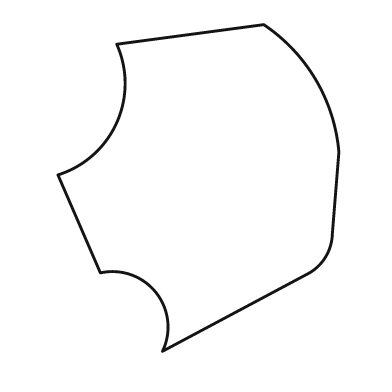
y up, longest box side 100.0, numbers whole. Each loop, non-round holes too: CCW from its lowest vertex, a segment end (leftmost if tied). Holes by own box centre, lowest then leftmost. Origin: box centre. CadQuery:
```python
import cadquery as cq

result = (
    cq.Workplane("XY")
    .moveTo(-11.0, -50.0)
    .lineTo(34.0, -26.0)
    .threePointArc((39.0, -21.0), (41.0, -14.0))
    .lineTo(43.0, 11.0)
    .threePointArc((36.0, 33.0), (20.0, 50.0))
    .lineTo(-25.0, 44.0)
    .threePointArc((-25.0, 20.0), (-43.0, 4.0))
    .lineTo(-30.0, -26.0)
    .threePointArc((-13.0, -32.0), (-11.0, -50.0))
    .close()
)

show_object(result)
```